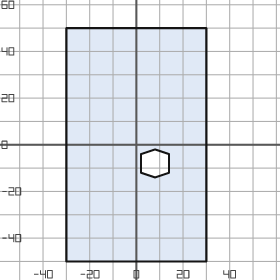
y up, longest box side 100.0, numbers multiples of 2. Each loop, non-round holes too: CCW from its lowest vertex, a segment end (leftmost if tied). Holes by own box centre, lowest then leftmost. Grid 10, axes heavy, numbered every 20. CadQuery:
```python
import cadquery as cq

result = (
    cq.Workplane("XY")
    .moveTo(-30.0, -50.0)
    .lineTo(30.0, -50.0)
    .lineTo(30.0, 50.0)
    .lineTo(-30.0, 50.0)
    .close()
    .moveTo(8.0, -14.0)
    .lineTo(14.0, -12.0)
    .lineTo(14.0, -4.0)
    .lineTo(8.0, -2.0)
    .lineTo(2.0, -4.0)
    .lineTo(2.0, -12.0)
    .close()
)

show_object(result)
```